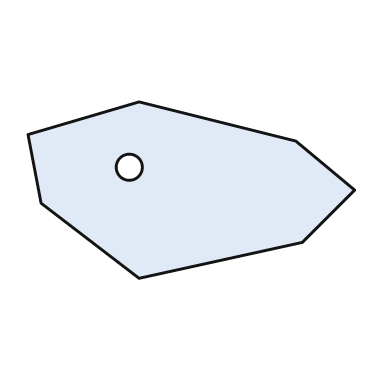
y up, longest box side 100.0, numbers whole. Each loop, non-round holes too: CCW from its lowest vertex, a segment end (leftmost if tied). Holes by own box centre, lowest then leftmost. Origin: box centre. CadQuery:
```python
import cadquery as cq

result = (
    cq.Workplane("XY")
    .moveTo(-16.0, -27.0)
    .lineTo(34.0, -16.0)
    .lineTo(50.0, 0.0)
    .lineTo(32.0, 15.0)
    .lineTo(-16.0, 27.0)
    .lineTo(-50.0, 17.0)
    .lineTo(-46.0, -4.0)
    .close()
    .moveTo(-19.0, 7.0)
    .circle(4.0)
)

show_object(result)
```